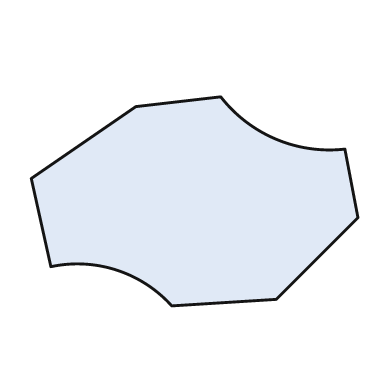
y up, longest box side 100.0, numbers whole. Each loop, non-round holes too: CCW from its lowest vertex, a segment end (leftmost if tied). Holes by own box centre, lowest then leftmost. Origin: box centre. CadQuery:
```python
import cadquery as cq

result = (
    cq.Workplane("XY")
    .moveTo(-7.0, -32.0)
    .lineTo(25.0, -30.0)
    .lineTo(50.0, -5.0)
    .lineTo(46.0, 16.0)
    .threePointArc((25.0, 19.0), (8.0, 32.0))
    .lineTo(-18.0, 29.0)
    .lineTo(-50.0, 7.0)
    .lineTo(-44.0, -20.0)
    .threePointArc((-24.0, -21.0), (-7.0, -32.0))
    .close()
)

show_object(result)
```